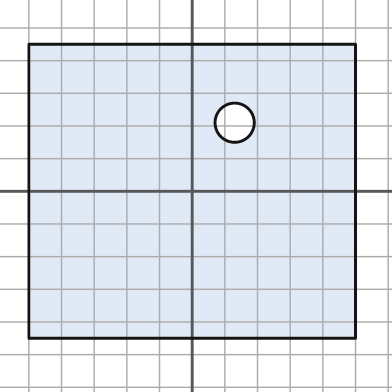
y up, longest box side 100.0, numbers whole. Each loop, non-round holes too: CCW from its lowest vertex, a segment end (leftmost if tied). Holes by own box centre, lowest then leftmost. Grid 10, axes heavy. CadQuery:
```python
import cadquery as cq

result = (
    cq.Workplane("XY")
    .moveTo(-50.0, -45.0)
    .lineTo(50.0, -45.0)
    .lineTo(50.0, 45.0)
    .lineTo(-50.0, 45.0)
    .close()
    .moveTo(13.0, 21.0)
    .circle(6.0)
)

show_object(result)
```